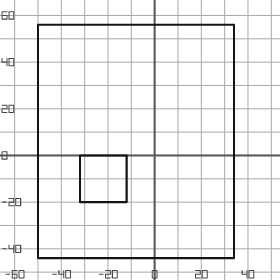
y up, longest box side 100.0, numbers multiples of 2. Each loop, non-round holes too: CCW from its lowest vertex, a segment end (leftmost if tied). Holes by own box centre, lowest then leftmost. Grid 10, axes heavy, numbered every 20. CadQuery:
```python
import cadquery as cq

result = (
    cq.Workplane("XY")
    .moveTo(-50.0, -44.0)
    .lineTo(34.0, -44.0)
    .lineTo(34.0, 56.0)
    .lineTo(-50.0, 56.0)
    .close()
    .moveTo(-32.0, -20.0)
    .lineTo(-12.0, -20.0)
    .lineTo(-12.0, 0.0)
    .lineTo(-32.0, 0.0)
    .close()
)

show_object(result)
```